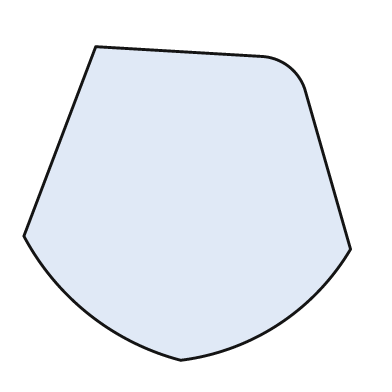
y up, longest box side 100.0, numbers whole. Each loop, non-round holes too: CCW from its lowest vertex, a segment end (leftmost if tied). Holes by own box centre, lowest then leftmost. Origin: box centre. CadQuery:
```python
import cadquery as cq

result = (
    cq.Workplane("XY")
    .moveTo(-2.0, -48.0)
    .threePointArc((28.0, -37.0), (50.0, -14.0))
    .lineTo(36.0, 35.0)
    .threePointArc((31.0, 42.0), (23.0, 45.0))
    .lineTo(-28.0, 48.0)
    .lineTo(-50.0, -10.0)
    .threePointArc((-30.0, -34.0), (-2.0, -48.0))
    .close()
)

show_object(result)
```